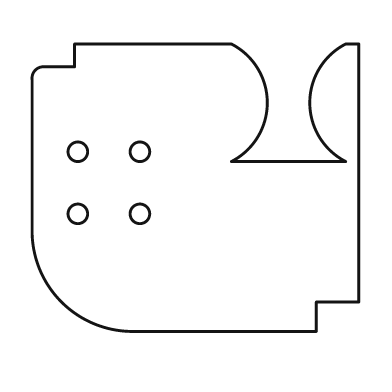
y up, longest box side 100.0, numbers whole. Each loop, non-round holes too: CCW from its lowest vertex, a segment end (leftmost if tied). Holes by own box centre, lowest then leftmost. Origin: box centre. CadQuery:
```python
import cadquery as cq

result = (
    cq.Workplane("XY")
    .moveTo(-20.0, -44.0)
    .lineTo(37.0, -44.0)
    .lineTo(37.0, -35.0)
    .lineTo(50.0, -35.0)
    .lineTo(50.0, 44.0)
    .lineTo(46.0, 44.0)
    .threePointArc((35.0, 26.0), (46.0, 8.0))
    .lineTo(11.0, 8.0)
    .threePointArc((22.0, 26.0), (11.0, 44.0))
    .lineTo(-37.0, 44.0)
    .lineTo(-37.0, 37.0)
    .lineTo(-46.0, 37.0)
    .threePointArc((-49.0, 36.0), (-50.0, 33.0))
    .lineTo(-50.0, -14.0)
    .threePointArc((-41.0, -35.0), (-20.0, -44.0))
    .close()
    .moveTo(-36.0, -8.0)
    .circle(3.0)
    .moveTo(-17.0, -8.0)
    .circle(3.0)
    .moveTo(-36.0, 11.0)
    .circle(3.0)
    .moveTo(-17.0, 11.0)
    .circle(3.0)
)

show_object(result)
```